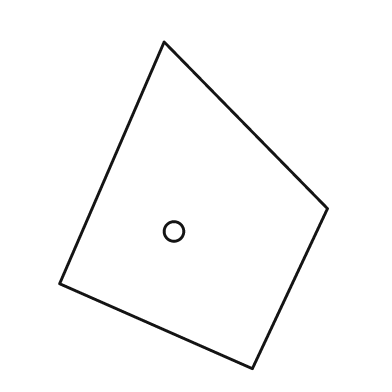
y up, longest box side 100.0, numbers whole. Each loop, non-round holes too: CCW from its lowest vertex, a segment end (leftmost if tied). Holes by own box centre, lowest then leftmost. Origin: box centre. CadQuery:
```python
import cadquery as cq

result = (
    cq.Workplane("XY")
    .moveTo(18.0, -50.0)
    .lineTo(41.0, -1.0)
    .lineTo(-9.0, 50.0)
    .lineTo(-41.0, -24.0)
    .close()
    .moveTo(-6.0, -8.0)
    .circle(3.0)
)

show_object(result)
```